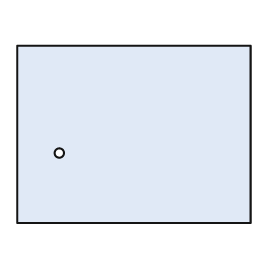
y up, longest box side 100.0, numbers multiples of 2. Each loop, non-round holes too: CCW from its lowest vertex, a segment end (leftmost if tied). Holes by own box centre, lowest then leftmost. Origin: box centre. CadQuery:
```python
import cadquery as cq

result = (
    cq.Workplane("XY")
    .moveTo(-50.0, -38.0)
    .lineTo(50.0, -38.0)
    .lineTo(50.0, 38.0)
    .lineTo(-50.0, 38.0)
    .close()
    .moveTo(-32.0, -8.0)
    .circle(2.0)
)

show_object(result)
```